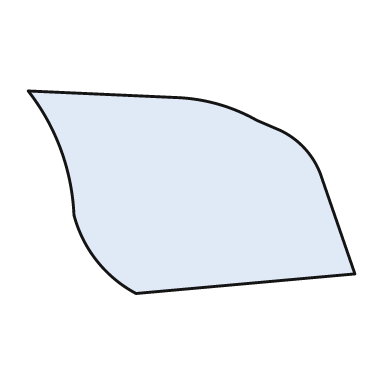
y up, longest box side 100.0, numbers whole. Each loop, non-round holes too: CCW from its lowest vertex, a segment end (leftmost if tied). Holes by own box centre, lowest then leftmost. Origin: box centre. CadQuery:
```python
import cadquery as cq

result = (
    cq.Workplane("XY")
    .moveTo(-17.0, -31.0)
    .lineTo(50.0, -25.0)
    .lineTo(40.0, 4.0)
    .threePointArc((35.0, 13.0), (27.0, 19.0))
    .lineTo(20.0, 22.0)
    .threePointArc((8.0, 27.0), (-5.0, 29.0))
    .lineTo(-50.0, 31.0)
    .threePointArc((-40.0, 13.0), (-36.0, -7.0))
    .threePointArc((-29.0, -21.0), (-17.0, -31.0))
    .close()
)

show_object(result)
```